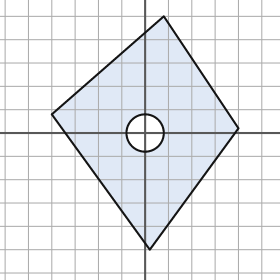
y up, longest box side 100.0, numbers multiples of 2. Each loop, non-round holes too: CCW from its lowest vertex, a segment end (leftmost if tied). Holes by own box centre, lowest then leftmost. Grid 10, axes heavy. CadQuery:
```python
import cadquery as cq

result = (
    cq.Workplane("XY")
    .moveTo(2.0, -50.0)
    .lineTo(40.0, 2.0)
    .lineTo(8.0, 50.0)
    .lineTo(-40.0, 8.0)
    .close()
    .moveTo(0.0, 0.0)
    .circle(8.0)
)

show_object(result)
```